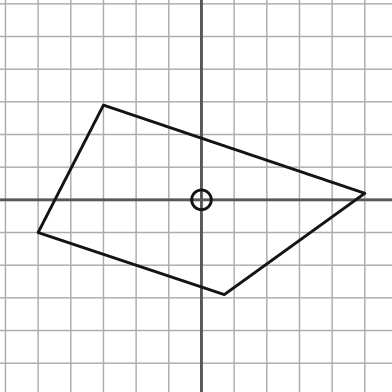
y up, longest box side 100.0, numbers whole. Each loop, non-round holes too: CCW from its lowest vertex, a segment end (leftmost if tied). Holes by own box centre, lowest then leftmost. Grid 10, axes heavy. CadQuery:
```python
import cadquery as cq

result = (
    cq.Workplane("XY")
    .moveTo(7.0, -29.0)
    .lineTo(50.0, 2.0)
    .lineTo(-30.0, 29.0)
    .lineTo(-50.0, -10.0)
    .close()
    .moveTo(0.0, 0.0)
    .circle(3.0)
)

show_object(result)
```